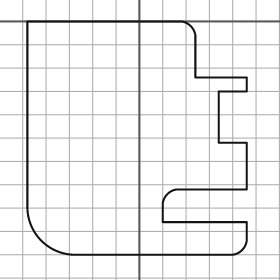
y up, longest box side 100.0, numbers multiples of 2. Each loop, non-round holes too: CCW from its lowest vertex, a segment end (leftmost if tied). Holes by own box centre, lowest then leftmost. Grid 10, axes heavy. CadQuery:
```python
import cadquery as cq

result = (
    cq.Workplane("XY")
    .moveTo(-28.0, -100.0)
    .lineTo(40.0, -100.0)
    .threePointArc((44.0, -98.0), (46.0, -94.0))
    .lineTo(46.0, -86.0)
    .lineTo(10.0, -86.0)
    .lineTo(10.0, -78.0)
    .threePointArc((12.0, -74.0), (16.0, -72.0))
    .lineTo(46.0, -72.0)
    .lineTo(46.0, -52.0)
    .lineTo(34.0, -52.0)
    .lineTo(34.0, -30.0)
    .lineTo(46.0, -30.0)
    .lineTo(46.0, -24.0)
    .lineTo(24.0, -24.0)
    .lineTo(24.0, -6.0)
    .threePointArc((22.0, -2.0), (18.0, 0.0))
    .lineTo(-48.0, 0.0)
    .lineTo(-48.0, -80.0)
    .threePointArc((-42.0, -94.0), (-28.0, -100.0))
    .close()
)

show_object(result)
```